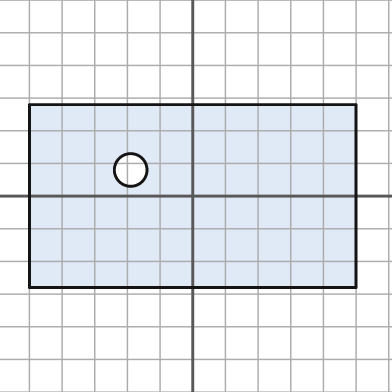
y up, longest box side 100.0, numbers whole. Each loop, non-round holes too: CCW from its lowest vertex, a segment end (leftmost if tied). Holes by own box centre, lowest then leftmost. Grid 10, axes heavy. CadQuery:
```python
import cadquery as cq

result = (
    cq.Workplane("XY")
    .moveTo(-50.0, -28.0)
    .lineTo(50.0, -28.0)
    .lineTo(50.0, 28.0)
    .lineTo(-50.0, 28.0)
    .close()
    .moveTo(-19.0, 8.0)
    .circle(5.0)
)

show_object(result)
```